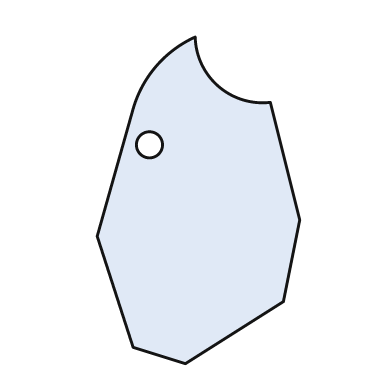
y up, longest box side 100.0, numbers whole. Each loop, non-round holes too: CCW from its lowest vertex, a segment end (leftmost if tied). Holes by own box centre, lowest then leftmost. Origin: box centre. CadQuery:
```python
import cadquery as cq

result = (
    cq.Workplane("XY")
    .moveTo(-4.0, -50.0)
    .lineTo(26.0, -31.0)
    .lineTo(31.0, -6.0)
    .lineTo(22.0, 30.0)
    .threePointArc((6.0, 35.0), (-1.0, 50.0))
    .threePointArc((-13.0, 41.0), (-20.0, 28.0))
    .lineTo(-31.0, -11.0)
    .lineTo(-20.0, -45.0)
    .close()
    .moveTo(-15.0, 17.0)
    .circle(4.0)
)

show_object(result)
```